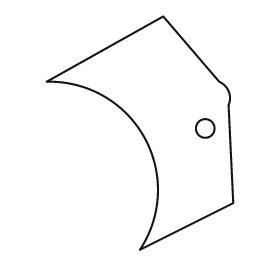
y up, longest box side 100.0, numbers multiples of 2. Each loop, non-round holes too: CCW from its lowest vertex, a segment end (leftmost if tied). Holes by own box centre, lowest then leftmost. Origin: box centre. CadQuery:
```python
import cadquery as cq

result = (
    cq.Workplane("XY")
    .moveTo(0.0, -50.0)
    .lineTo(40.0, -30.0)
    .lineTo(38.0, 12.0)
    .threePointArc((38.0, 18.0), (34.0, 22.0))
    .lineTo(10.0, 50.0)
    .lineTo(-40.0, 22.0)
    .threePointArc((2.0, -2.0), (0.0, -50.0))
    .close()
    .moveTo(28.0, 2.0)
    .circle(4.0)
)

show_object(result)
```